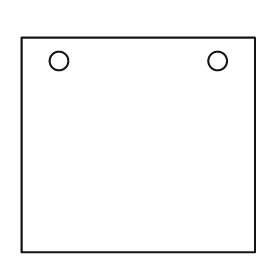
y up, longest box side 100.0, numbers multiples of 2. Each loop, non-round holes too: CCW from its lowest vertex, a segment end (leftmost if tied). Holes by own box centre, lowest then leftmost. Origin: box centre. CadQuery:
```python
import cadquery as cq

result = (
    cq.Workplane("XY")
    .moveTo(-50.0, -46.0)
    .lineTo(50.0, -46.0)
    .lineTo(50.0, 46.0)
    .lineTo(-50.0, 46.0)
    .close()
    .moveTo(-34.0, 36.0)
    .circle(4.0)
    .moveTo(34.0, 36.0)
    .circle(4.0)
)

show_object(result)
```